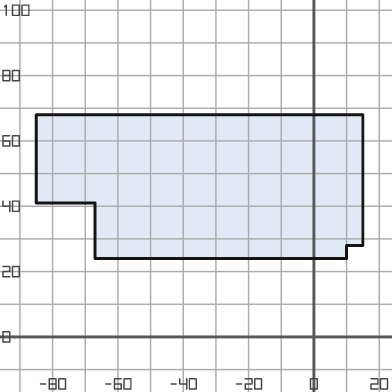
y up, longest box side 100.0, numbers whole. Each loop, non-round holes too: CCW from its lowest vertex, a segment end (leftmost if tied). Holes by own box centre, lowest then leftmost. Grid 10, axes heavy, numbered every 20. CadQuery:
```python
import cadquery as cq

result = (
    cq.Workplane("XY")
    .moveTo(-67.0, 24.0)
    .lineTo(10.0, 24.0)
    .lineTo(10.0, 28.0)
    .lineTo(15.0, 28.0)
    .lineTo(15.0, 68.0)
    .lineTo(-85.0, 68.0)
    .lineTo(-85.0, 41.0)
    .lineTo(-67.0, 41.0)
    .close()
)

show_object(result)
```